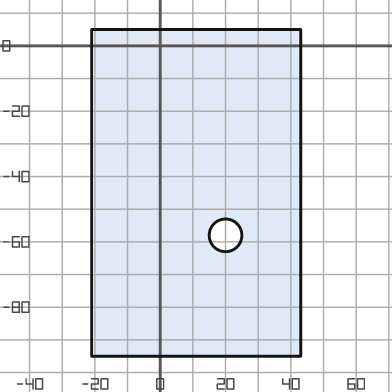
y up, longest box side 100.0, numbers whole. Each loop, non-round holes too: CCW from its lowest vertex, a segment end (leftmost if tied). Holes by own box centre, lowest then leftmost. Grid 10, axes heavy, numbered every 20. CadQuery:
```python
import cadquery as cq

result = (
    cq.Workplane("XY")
    .moveTo(-21.0, -95.0)
    .lineTo(43.0, -95.0)
    .lineTo(43.0, 5.0)
    .lineTo(-21.0, 5.0)
    .close()
    .moveTo(20.0, -58.0)
    .circle(5.0)
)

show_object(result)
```